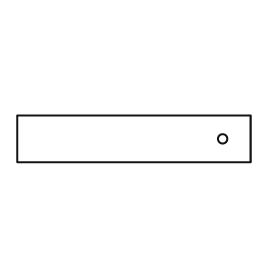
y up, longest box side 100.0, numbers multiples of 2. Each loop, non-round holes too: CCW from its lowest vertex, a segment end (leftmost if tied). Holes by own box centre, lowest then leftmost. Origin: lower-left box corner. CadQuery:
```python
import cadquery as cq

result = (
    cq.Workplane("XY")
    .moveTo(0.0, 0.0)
    .lineTo(100.0, 0.0)
    .lineTo(100.0, 20.0)
    .lineTo(0.0, 20.0)
    .close()
    .moveTo(88.0, 10.0)
    .circle(2.0)
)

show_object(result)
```